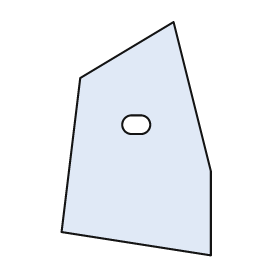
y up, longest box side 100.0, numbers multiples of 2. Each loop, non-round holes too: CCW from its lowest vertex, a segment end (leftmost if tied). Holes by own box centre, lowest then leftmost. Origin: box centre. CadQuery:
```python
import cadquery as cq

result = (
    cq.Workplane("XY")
    .moveTo(32.0, -50.0)
    .lineTo(32.0, -14.0)
    .lineTo(16.0, 50.0)
    .lineTo(-24.0, 26.0)
    .lineTo(-32.0, -40.0)
    .close()
    .moveTo(-2.0, 2.0)
    .lineTo(2.0, 2.0)
    .threePointArc((6.0, 6.0), (2.0, 10.0))
    .lineTo(-2.0, 10.0)
    .threePointArc((-6.0, 6.0), (-2.0, 2.0))
    .close()
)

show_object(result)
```